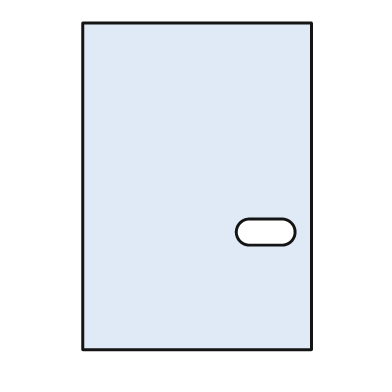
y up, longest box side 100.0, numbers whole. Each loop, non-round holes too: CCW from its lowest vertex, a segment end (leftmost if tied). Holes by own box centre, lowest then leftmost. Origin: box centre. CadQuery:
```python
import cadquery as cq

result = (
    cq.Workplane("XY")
    .moveTo(-35.0, -50.0)
    .lineTo(35.0, -50.0)
    .lineTo(35.0, 50.0)
    .lineTo(-35.0, 50.0)
    .close()
    .moveTo(16.0, -18.0)
    .lineTo(26.0, -18.0)
    .threePointArc((30.0, -14.0), (26.0, -10.0))
    .lineTo(16.0, -10.0)
    .threePointArc((12.0, -14.0), (16.0, -18.0))
    .close()
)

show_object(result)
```